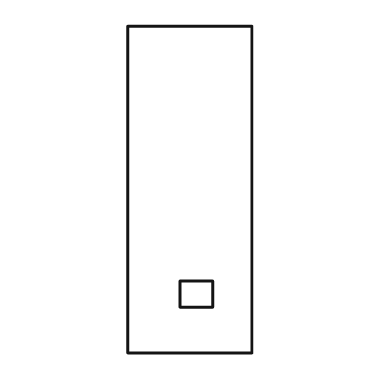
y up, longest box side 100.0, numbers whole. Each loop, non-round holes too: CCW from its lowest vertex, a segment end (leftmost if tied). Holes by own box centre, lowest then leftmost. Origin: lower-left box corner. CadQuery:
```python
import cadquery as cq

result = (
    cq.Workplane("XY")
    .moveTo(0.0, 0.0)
    .lineTo(38.0, 0.0)
    .lineTo(38.0, 100.0)
    .lineTo(0.0, 100.0)
    .close()
    .moveTo(16.0, 14.0)
    .lineTo(26.0, 14.0)
    .lineTo(26.0, 22.0)
    .lineTo(16.0, 22.0)
    .close()
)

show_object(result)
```